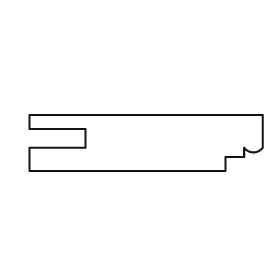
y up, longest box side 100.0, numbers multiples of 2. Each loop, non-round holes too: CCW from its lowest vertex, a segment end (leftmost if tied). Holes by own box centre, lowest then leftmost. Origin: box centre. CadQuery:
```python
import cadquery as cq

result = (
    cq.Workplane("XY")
    .moveTo(-50.0, -12.0)
    .lineTo(34.0, -12.0)
    .lineTo(34.0, -6.0)
    .lineTo(42.0, -6.0)
    .lineTo(42.0, -2.0)
    .threePointArc((46.0, -4.0), (50.0, -2.0))
    .lineTo(50.0, 12.0)
    .lineTo(-50.0, 12.0)
    .lineTo(-50.0, 6.0)
    .lineTo(-26.0, 6.0)
    .lineTo(-26.0, -2.0)
    .lineTo(-50.0, -2.0)
    .close()
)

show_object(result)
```